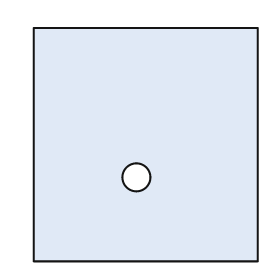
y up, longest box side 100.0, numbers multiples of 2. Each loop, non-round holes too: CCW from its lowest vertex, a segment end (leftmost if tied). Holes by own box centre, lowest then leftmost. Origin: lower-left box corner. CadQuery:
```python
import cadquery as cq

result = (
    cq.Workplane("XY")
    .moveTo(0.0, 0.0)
    .lineTo(96.0, 0.0)
    .lineTo(96.0, 100.0)
    .lineTo(0.0, 100.0)
    .close()
    .moveTo(44.0, 36.0)
    .circle(6.0)
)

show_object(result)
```